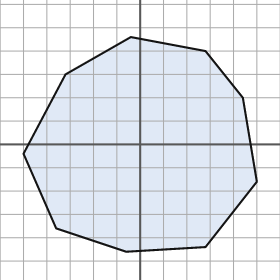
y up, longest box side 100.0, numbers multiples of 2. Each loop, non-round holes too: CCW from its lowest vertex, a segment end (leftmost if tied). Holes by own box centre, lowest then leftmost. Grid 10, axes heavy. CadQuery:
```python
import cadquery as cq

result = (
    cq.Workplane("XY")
    .moveTo(-6.0, -46.0)
    .lineTo(28.0, -44.0)
    .lineTo(50.0, -16.0)
    .lineTo(44.0, 20.0)
    .lineTo(28.0, 40.0)
    .lineTo(-4.0, 46.0)
    .lineTo(-32.0, 30.0)
    .lineTo(-50.0, -4.0)
    .lineTo(-36.0, -36.0)
    .close()
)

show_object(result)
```